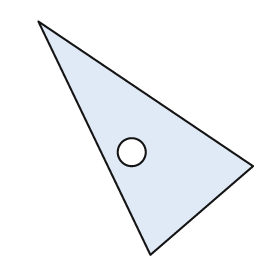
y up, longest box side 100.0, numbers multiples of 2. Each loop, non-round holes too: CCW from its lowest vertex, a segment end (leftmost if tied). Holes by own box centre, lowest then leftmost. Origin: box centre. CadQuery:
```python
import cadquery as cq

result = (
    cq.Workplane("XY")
    .moveTo(2.0, -50.0)
    .lineTo(46.0, -12.0)
    .lineTo(-46.0, 50.0)
    .close()
    .moveTo(-6.0, -6.0)
    .circle(6.0)
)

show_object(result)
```